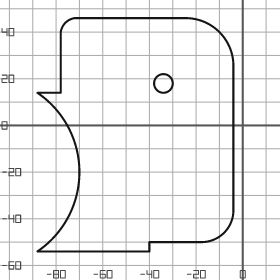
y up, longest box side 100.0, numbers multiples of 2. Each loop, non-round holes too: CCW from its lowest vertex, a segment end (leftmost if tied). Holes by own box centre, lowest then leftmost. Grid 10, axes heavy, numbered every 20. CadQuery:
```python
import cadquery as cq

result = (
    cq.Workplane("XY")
    .moveTo(-88.0, -54.0)
    .lineTo(-40.0, -54.0)
    .lineTo(-40.0, -50.0)
    .lineTo(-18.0, -50.0)
    .threePointArc((-8.0, -46.0), (-4.0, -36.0))
    .lineTo(-4.0, 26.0)
    .threePointArc((-10.0, 40.0), (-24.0, 46.0))
    .lineTo(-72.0, 46.0)
    .threePointArc((-76.0, 44.0), (-78.0, 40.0))
    .lineTo(-78.0, 14.0)
    .lineTo(-88.0, 14.0)
    .threePointArc((-70.0, -20.0), (-88.0, -54.0))
    .close()
    .moveTo(-34.0, 18.0)
    .circle(4.0)
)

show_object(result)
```